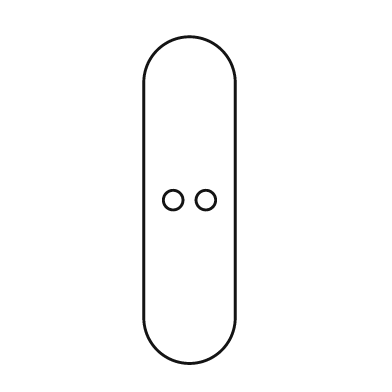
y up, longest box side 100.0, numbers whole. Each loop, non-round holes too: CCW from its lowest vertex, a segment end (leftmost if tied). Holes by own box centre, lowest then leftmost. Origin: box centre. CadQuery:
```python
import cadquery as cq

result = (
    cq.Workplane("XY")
    .moveTo(-14.0, -36.0)
    .threePointArc((0.0, -50.0), (14.0, -36.0))
    .lineTo(14.0, 36.0)
    .threePointArc((0.0, 50.0), (-14.0, 36.0))
    .close()
    .moveTo(-5.0, 0.0)
    .circle(3.0)
    .moveTo(5.0, 0.0)
    .circle(3.0)
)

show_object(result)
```